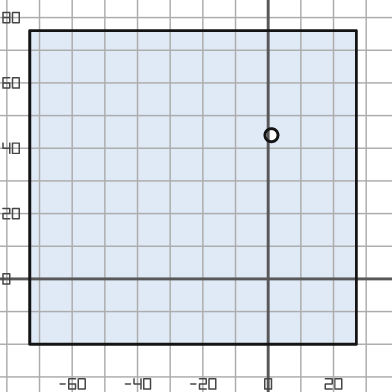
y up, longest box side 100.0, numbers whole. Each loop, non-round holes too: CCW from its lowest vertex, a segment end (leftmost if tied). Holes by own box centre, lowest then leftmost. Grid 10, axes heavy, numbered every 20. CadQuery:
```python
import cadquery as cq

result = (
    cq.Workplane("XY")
    .moveTo(-73.0, -20.0)
    .lineTo(27.0, -20.0)
    .lineTo(27.0, 76.0)
    .lineTo(-73.0, 76.0)
    .close()
    .moveTo(1.0, 44.0)
    .circle(2.0)
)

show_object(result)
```